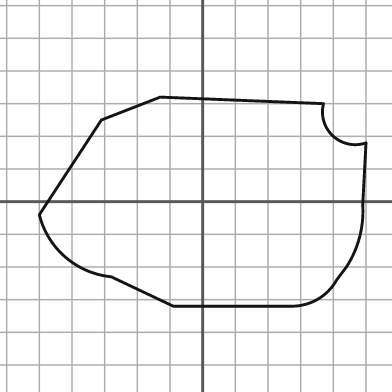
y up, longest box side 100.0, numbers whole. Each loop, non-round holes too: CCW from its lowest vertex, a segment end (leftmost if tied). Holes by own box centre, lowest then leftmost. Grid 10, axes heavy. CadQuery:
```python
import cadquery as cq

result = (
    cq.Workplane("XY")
    .moveTo(-9.0, -32.0)
    .lineTo(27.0, -32.0)
    .threePointArc((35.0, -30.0), (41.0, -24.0))
    .lineTo(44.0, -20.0)
    .threePointArc((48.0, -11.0), (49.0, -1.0))
    .lineTo(50.0, 18.0)
    .threePointArc((40.0, 20.0), (37.0, 30.0))
    .lineTo(-13.0, 32.0)
    .lineTo(-31.0, 25.0)
    .lineTo(-50.0, -4.0)
    .threePointArc((-42.0, -17.0), (-28.0, -23.0))
    .close()
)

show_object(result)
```